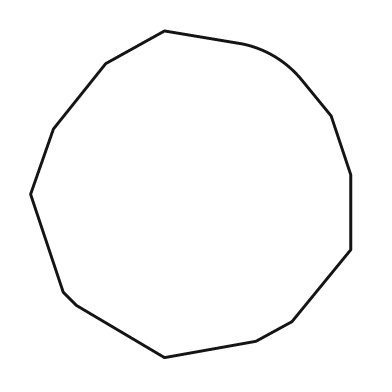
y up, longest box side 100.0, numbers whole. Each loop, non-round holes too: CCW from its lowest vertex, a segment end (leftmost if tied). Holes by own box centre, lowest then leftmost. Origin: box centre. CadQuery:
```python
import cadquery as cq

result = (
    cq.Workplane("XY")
    .moveTo(-8.0, -50.0)
    .lineTo(20.0, -45.0)
    .lineTo(31.0, -39.0)
    .lineTo(49.0, -17.0)
    .lineTo(49.0, 6.0)
    .lineTo(43.0, 24.0)
    .lineTo(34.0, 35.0)
    .threePointArc((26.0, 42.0), (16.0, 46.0))
    .lineTo(-8.0, 50.0)
    .lineTo(-26.0, 40.0)
    .lineTo(-42.0, 20.0)
    .lineTo(-49.0, 0.0)
    .lineTo(-39.0, -30.0)
    .lineTo(-35.0, -34.0)
    .close()
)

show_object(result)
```